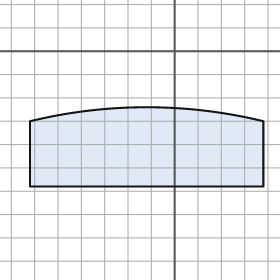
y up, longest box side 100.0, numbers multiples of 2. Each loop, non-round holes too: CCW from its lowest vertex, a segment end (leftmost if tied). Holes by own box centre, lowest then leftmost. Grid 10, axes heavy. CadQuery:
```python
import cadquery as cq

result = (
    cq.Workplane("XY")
    .moveTo(-62.0, -58.0)
    .lineTo(38.0, -58.0)
    .lineTo(38.0, -30.0)
    .threePointArc((-12.0, -24.0), (-62.0, -30.0))
    .close()
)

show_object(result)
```